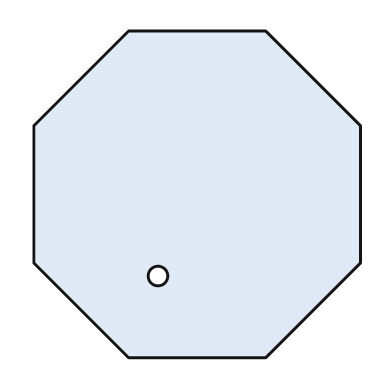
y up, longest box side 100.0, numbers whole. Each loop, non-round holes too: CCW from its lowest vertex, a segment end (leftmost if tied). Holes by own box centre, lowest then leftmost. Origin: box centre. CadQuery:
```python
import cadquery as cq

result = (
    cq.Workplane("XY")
    .moveTo(-21.0, -50.0)
    .lineTo(21.0, -50.0)
    .lineTo(50.0, -21.0)
    .lineTo(50.0, 21.0)
    .lineTo(21.0, 50.0)
    .lineTo(-21.0, 50.0)
    .lineTo(-50.0, 21.0)
    .lineTo(-50.0, -21.0)
    .close()
    .moveTo(-12.0, -25.0)
    .circle(3.0)
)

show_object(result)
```